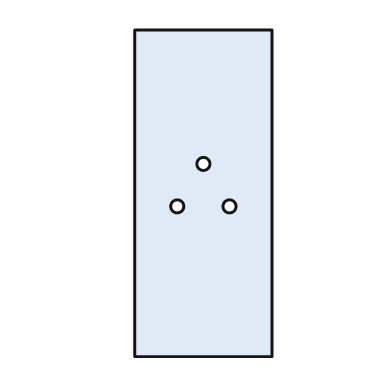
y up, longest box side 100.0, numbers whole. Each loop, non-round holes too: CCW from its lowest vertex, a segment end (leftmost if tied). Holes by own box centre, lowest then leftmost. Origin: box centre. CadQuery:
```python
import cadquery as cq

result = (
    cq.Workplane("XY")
    .moveTo(-21.0, -50.0)
    .lineTo(21.0, -50.0)
    .lineTo(21.0, 50.0)
    .lineTo(-21.0, 50.0)
    .close()
    .moveTo(-8.0, -4.0)
    .circle(2.0)
    .moveTo(8.0, -4.0)
    .circle(2.0)
    .moveTo(0.0, 9.0)
    .circle(2.0)
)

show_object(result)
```